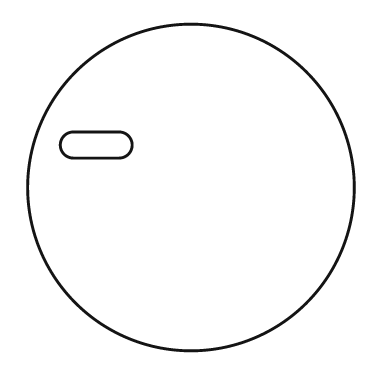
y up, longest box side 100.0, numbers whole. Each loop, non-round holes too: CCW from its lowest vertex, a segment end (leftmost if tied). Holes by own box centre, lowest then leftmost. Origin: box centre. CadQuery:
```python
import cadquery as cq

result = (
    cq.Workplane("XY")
    .moveTo(0.0, 0.0)
    .circle(50.0)
    .moveTo(-36.0, 9.0)
    .lineTo(-22.0, 9.0)
    .threePointArc((-18.0, 13.0), (-22.0, 17.0))
    .lineTo(-36.0, 17.0)
    .threePointArc((-40.0, 13.0), (-36.0, 9.0))
    .close()
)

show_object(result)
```